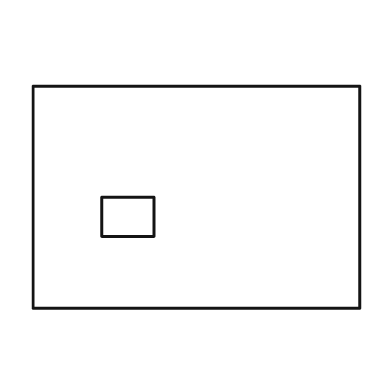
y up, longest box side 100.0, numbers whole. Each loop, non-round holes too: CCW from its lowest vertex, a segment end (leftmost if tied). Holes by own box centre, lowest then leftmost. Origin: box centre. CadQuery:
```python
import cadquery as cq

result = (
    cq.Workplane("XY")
    .moveTo(-50.0, -34.0)
    .lineTo(50.0, -34.0)
    .lineTo(50.0, 34.0)
    .lineTo(-50.0, 34.0)
    .close()
    .moveTo(-29.0, -12.0)
    .lineTo(-13.0, -12.0)
    .lineTo(-13.0, 0.0)
    .lineTo(-29.0, 0.0)
    .close()
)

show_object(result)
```